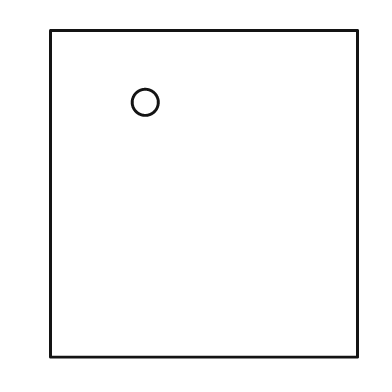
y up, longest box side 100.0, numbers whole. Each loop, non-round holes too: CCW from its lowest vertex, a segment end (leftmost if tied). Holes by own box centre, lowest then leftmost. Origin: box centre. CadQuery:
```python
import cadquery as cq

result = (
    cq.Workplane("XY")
    .moveTo(-47.0, -50.0)
    .lineTo(47.0, -50.0)
    .lineTo(47.0, 50.0)
    .lineTo(-47.0, 50.0)
    .close()
    .moveTo(-18.0, 28.0)
    .circle(4.0)
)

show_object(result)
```